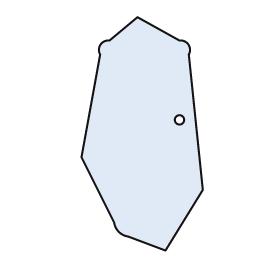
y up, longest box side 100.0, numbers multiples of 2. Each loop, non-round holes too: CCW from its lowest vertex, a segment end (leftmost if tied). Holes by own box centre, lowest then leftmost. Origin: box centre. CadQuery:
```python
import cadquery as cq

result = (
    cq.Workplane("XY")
    .moveTo(10.0, -50.0)
    .lineTo(26.0, -24.0)
    .lineTo(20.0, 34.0)
    .threePointArc((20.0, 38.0), (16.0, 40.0))
    .lineTo(-2.0, 50.0)
    .lineTo(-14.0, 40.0)
    .threePointArc((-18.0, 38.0), (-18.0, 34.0))
    .lineTo(-26.0, -10.0)
    .lineTo(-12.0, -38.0)
    .threePointArc((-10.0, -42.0), (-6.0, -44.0))
    .close()
    .moveTo(16.0, 6.0)
    .circle(2.0)
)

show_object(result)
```